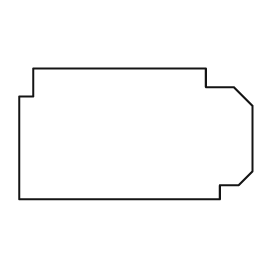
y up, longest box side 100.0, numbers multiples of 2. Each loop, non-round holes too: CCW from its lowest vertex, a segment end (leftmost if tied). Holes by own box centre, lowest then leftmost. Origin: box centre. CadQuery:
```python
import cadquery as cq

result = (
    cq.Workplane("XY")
    .moveTo(-50.0, -28.0)
    .lineTo(36.0, -28.0)
    .lineTo(36.0, -22.0)
    .lineTo(44.0, -22.0)
    .lineTo(50.0, -16.0)
    .lineTo(50.0, 12.0)
    .lineTo(42.0, 20.0)
    .lineTo(30.0, 20.0)
    .lineTo(30.0, 28.0)
    .lineTo(-44.0, 28.0)
    .lineTo(-44.0, 16.0)
    .lineTo(-50.0, 16.0)
    .close()
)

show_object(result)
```